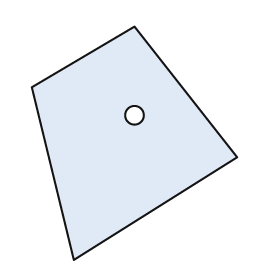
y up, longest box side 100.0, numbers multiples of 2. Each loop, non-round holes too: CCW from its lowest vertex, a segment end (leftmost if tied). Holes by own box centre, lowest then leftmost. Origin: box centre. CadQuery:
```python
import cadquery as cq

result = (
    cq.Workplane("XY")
    .moveTo(-26.0, -50.0)
    .lineTo(44.0, -6.0)
    .lineTo(0.0, 50.0)
    .lineTo(-44.0, 24.0)
    .close()
    .moveTo(0.0, 12.0)
    .circle(4.0)
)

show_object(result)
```